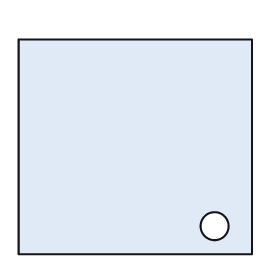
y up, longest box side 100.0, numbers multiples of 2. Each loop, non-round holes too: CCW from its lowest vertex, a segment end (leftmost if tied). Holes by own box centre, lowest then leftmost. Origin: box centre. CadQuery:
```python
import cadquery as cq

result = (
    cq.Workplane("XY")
    .moveTo(-50.0, -46.0)
    .lineTo(50.0, -46.0)
    .lineTo(50.0, 46.0)
    .lineTo(-50.0, 46.0)
    .close()
    .moveTo(34.0, -34.0)
    .circle(6.0)
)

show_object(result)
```